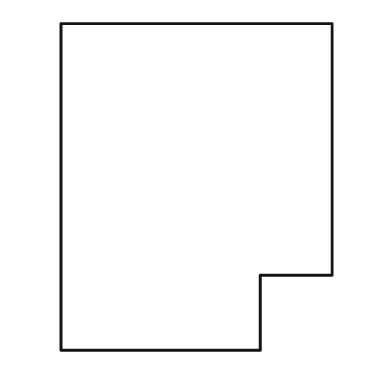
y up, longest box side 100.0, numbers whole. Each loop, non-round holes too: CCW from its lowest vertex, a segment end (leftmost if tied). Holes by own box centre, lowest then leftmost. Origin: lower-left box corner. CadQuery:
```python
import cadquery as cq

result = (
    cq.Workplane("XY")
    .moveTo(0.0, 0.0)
    .lineTo(61.0, 0.0)
    .lineTo(61.0, 23.0)
    .lineTo(83.0, 23.0)
    .lineTo(83.0, 100.0)
    .lineTo(0.0, 100.0)
    .close()
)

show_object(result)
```